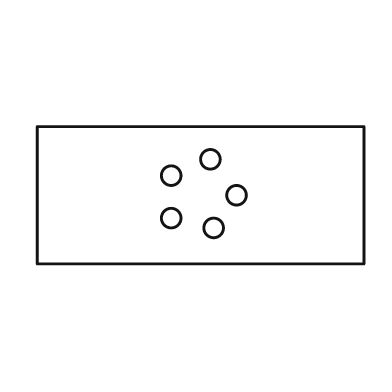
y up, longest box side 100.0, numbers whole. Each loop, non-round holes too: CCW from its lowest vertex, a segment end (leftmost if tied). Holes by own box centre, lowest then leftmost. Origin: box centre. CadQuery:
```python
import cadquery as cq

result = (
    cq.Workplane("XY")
    .moveTo(-50.0, -21.0)
    .lineTo(50.0, -21.0)
    .lineTo(50.0, 21.0)
    .lineTo(-50.0, 21.0)
    .close()
    .moveTo(4.0, -10.0)
    .circle(3.0)
    .moveTo(-9.0, -7.0)
    .circle(3.0)
    .moveTo(11.0, 0.0)
    .circle(3.0)
    .moveTo(-9.0, 6.0)
    .circle(3.0)
    .moveTo(3.0, 11.0)
    .circle(3.0)
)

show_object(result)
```